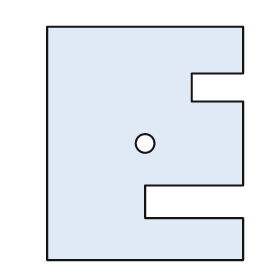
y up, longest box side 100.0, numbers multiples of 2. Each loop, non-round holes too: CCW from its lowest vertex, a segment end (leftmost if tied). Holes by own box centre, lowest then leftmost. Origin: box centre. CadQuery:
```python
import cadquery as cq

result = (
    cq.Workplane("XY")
    .moveTo(-42.0, -50.0)
    .lineTo(42.0, -50.0)
    .lineTo(42.0, -32.0)
    .lineTo(0.0, -32.0)
    .lineTo(0.0, -18.0)
    .lineTo(42.0, -18.0)
    .lineTo(42.0, 18.0)
    .lineTo(20.0, 18.0)
    .lineTo(20.0, 30.0)
    .lineTo(42.0, 30.0)
    .lineTo(42.0, 50.0)
    .lineTo(-42.0, 50.0)
    .close()
    .moveTo(0.0, 0.0)
    .circle(4.0)
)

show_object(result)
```